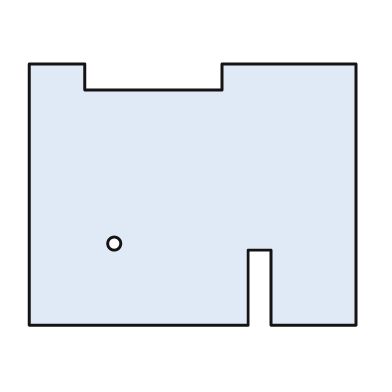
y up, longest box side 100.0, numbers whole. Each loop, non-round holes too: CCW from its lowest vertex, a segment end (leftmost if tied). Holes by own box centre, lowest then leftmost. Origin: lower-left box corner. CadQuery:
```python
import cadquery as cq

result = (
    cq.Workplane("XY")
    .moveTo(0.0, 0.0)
    .lineTo(67.0, 0.0)
    .lineTo(67.0, 23.0)
    .lineTo(74.0, 23.0)
    .lineTo(74.0, 0.0)
    .lineTo(100.0, 0.0)
    .lineTo(100.0, 80.0)
    .lineTo(59.0, 80.0)
    .lineTo(59.0, 72.0)
    .lineTo(17.0, 72.0)
    .lineTo(17.0, 80.0)
    .lineTo(0.0, 80.0)
    .close()
    .moveTo(26.0, 25.0)
    .circle(2.0)
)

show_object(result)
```